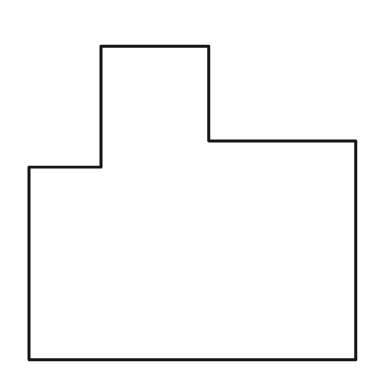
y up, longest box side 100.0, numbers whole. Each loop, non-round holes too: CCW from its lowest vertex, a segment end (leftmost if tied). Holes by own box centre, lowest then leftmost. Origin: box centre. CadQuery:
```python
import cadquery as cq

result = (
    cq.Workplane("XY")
    .moveTo(-50.0, -48.0)
    .lineTo(50.0, -48.0)
    .lineTo(50.0, 19.0)
    .lineTo(5.0, 19.0)
    .lineTo(5.0, 48.0)
    .lineTo(-28.0, 48.0)
    .lineTo(-28.0, 11.0)
    .lineTo(-50.0, 11.0)
    .close()
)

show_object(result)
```